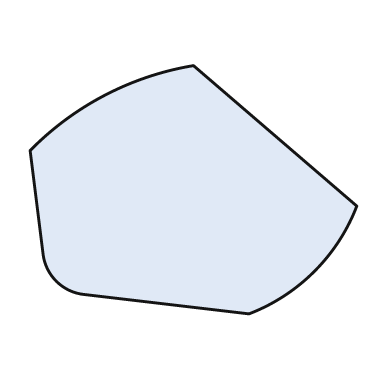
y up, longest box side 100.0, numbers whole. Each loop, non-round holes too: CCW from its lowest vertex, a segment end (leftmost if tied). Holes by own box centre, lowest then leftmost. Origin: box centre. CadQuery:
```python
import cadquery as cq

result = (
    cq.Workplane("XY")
    .moveTo(17.0, -38.0)
    .threePointArc((37.0, -25.0), (50.0, -5.0))
    .lineTo(0.0, 38.0)
    .threePointArc((-27.0, 29.0), (-50.0, 12.0))
    .lineTo(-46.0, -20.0)
    .threePointArc((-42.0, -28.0), (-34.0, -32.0))
    .close()
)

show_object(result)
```